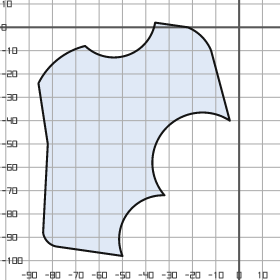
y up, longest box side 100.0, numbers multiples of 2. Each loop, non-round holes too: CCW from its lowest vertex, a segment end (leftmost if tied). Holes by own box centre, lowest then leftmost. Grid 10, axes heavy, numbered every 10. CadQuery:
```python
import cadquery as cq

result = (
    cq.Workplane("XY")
    .moveTo(-50.0, -98.0)
    .threePointArc((-48.0, -80.0), (-32.0, -72.0))
    .threePointArc((-32.0, -44.0), (-4.0, -40.0))
    .lineTo(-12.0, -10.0)
    .threePointArc((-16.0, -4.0), (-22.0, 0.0))
    .lineTo(-36.0, 2.0)
    .threePointArc((-48.0, -12.0), (-66.0, -8.0))
    .threePointArc((-78.0, -14.0), (-86.0, -24.0))
    .lineTo(-82.0, -50.0)
    .lineTo(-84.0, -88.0)
    .threePointArc((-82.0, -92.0), (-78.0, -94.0))
    .close()
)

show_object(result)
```